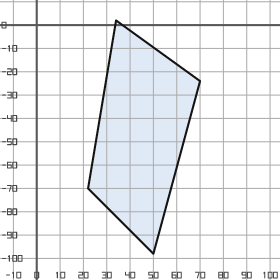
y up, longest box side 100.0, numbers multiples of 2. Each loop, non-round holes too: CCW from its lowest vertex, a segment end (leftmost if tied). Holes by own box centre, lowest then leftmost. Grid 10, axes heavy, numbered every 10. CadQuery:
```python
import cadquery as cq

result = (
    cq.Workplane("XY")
    .moveTo(50.0, -98.0)
    .lineTo(70.0, -24.0)
    .lineTo(34.0, 2.0)
    .lineTo(22.0, -70.0)
    .close()
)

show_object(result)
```